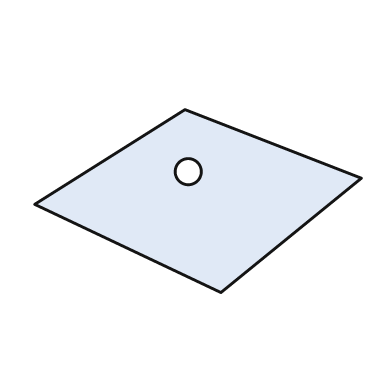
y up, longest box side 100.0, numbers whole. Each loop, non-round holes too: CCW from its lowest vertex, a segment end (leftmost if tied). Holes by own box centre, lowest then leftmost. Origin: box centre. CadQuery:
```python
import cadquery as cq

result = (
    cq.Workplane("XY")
    .moveTo(7.0, -28.0)
    .lineTo(50.0, 7.0)
    .lineTo(-4.0, 28.0)
    .lineTo(-50.0, -1.0)
    .close()
    .moveTo(-3.0, 9.0)
    .circle(4.0)
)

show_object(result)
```